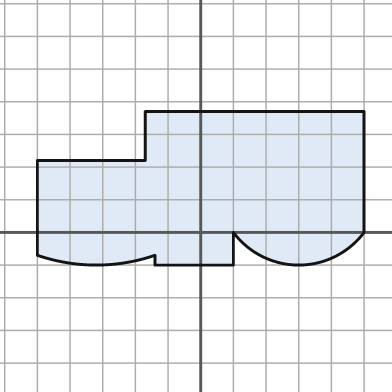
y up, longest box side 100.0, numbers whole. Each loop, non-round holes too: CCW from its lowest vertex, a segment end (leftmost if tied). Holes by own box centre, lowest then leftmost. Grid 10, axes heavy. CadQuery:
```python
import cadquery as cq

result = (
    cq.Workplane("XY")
    .moveTo(-14.0, -10.0)
    .lineTo(10.0, -10.0)
    .lineTo(10.0, 0.0)
    .threePointArc((30.0, -10.0), (50.0, 0.0))
    .lineTo(50.0, 37.0)
    .lineTo(-17.0, 37.0)
    .lineTo(-17.0, 22.0)
    .lineTo(-50.0, 22.0)
    .lineTo(-50.0, -7.0)
    .threePointArc((-32.0, -10.0), (-14.0, -7.0))
    .close()
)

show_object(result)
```